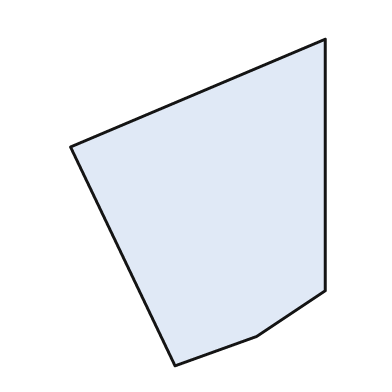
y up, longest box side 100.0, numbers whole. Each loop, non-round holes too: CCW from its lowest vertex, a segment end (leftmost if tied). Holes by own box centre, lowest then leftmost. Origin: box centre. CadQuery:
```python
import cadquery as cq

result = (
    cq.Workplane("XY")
    .moveTo(-7.0, -50.0)
    .lineTo(18.0, -41.0)
    .lineTo(39.0, -27.0)
    .lineTo(39.0, 50.0)
    .lineTo(-39.0, 17.0)
    .close()
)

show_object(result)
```